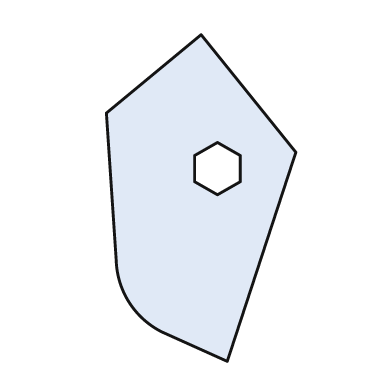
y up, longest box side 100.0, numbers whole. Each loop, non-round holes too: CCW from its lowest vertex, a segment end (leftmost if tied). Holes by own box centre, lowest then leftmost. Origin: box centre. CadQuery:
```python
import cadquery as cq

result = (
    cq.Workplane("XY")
    .moveTo(8.0, -50.0)
    .lineTo(29.0, 14.0)
    .lineTo(0.0, 50.0)
    .lineTo(-29.0, 26.0)
    .lineTo(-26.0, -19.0)
    .threePointArc((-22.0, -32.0), (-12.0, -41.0))
    .close()
    .moveTo(5.0, 1.0)
    .lineTo(12.0, 5.0)
    .lineTo(12.0, 13.0)
    .lineTo(5.0, 17.0)
    .lineTo(-2.0, 13.0)
    .lineTo(-2.0, 5.0)
    .close()
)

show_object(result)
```